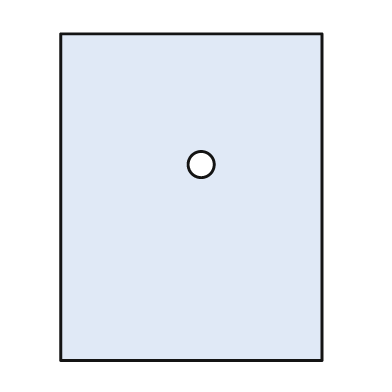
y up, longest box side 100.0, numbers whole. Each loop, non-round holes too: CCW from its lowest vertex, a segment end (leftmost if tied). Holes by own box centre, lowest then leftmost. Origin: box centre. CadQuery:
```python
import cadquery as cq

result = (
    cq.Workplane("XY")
    .moveTo(-40.0, -50.0)
    .lineTo(40.0, -50.0)
    .lineTo(40.0, 50.0)
    .lineTo(-40.0, 50.0)
    .close()
    .moveTo(3.0, 10.0)
    .circle(4.0)
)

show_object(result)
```